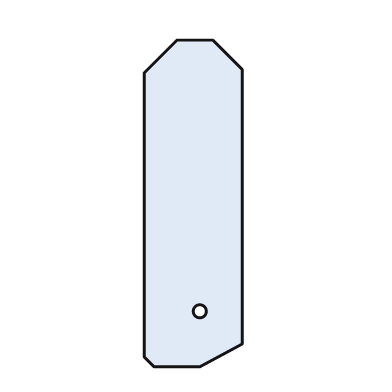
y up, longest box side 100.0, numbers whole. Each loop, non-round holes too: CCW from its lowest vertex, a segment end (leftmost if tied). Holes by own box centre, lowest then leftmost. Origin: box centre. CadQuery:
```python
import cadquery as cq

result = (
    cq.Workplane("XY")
    .moveTo(-12.0, -50.0)
    .lineTo(2.0, -50.0)
    .lineTo(15.0, -43.0)
    .lineTo(15.0, 41.0)
    .lineTo(6.0, 50.0)
    .lineTo(-5.0, 50.0)
    .lineTo(-15.0, 40.0)
    .lineTo(-15.0, -47.0)
    .close()
    .moveTo(2.0, -33.0)
    .circle(2.0)
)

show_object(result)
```